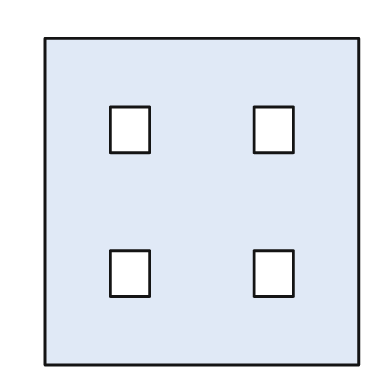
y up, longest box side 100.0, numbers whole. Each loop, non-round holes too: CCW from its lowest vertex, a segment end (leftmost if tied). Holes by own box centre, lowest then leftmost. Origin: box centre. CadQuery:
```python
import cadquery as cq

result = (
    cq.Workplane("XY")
    .moveTo(-48.0, -50.0)
    .lineTo(48.0, -50.0)
    .lineTo(48.0, 50.0)
    .lineTo(-48.0, 50.0)
    .close()
    .moveTo(-28.0, -29.0)
    .lineTo(-16.0, -29.0)
    .lineTo(-16.0, -15.0)
    .lineTo(-28.0, -15.0)
    .close()
    .moveTo(16.0, -29.0)
    .lineTo(28.0, -29.0)
    .lineTo(28.0, -15.0)
    .lineTo(16.0, -15.0)
    .close()
    .moveTo(-28.0, 15.0)
    .lineTo(-16.0, 15.0)
    .lineTo(-16.0, 29.0)
    .lineTo(-28.0, 29.0)
    .close()
    .moveTo(16.0, 15.0)
    .lineTo(28.0, 15.0)
    .lineTo(28.0, 29.0)
    .lineTo(16.0, 29.0)
    .close()
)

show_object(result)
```